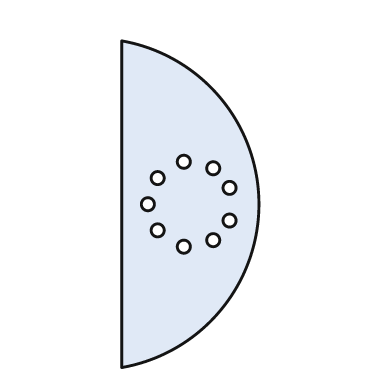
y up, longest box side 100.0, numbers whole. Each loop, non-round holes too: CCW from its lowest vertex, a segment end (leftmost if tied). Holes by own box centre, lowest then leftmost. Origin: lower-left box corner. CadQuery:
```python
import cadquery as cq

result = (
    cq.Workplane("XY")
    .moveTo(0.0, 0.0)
    .threePointArc((42.0, 50.0), (0.0, 100.0))
    .close()
    .moveTo(19.0, 37.0)
    .circle(2.0)
    .moveTo(28.0, 39.0)
    .circle(2.0)
    .moveTo(11.0, 42.0)
    .circle(2.0)
    .moveTo(33.0, 45.0)
    .circle(2.0)
    .moveTo(8.0, 50.0)
    .circle(2.0)
    .moveTo(33.0, 55.0)
    .circle(2.0)
    .moveTo(11.0, 58.0)
    .circle(2.0)
    .moveTo(28.0, 61.0)
    .circle(2.0)
    .moveTo(19.0, 63.0)
    .circle(2.0)
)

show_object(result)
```